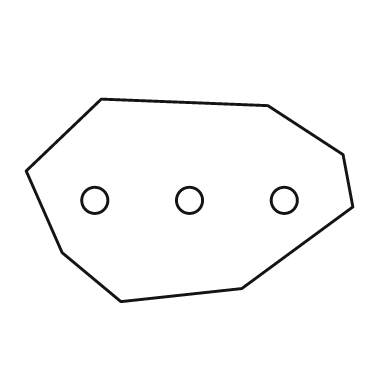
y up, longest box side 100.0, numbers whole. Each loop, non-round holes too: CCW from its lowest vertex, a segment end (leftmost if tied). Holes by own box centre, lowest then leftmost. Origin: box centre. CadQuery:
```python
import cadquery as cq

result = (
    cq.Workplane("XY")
    .moveTo(-21.0, -31.0)
    .lineTo(16.0, -27.0)
    .lineTo(50.0, -2.0)
    .lineTo(47.0, 14.0)
    .lineTo(24.0, 29.0)
    .lineTo(-27.0, 31.0)
    .lineTo(-50.0, 9.0)
    .lineTo(-39.0, -16.0)
    .close()
    .moveTo(-29.0, 0.0)
    .circle(4.0)
    .moveTo(0.0, 0.0)
    .circle(4.0)
    .moveTo(29.0, 0.0)
    .circle(4.0)
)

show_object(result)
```